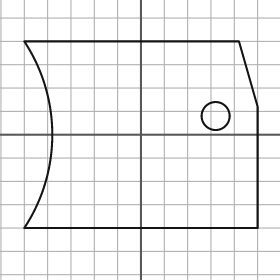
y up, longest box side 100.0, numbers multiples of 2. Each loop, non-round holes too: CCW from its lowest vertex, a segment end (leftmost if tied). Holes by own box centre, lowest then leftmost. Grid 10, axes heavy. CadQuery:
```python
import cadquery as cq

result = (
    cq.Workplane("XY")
    .moveTo(-50.0, -40.0)
    .lineTo(50.0, -40.0)
    .lineTo(50.0, 12.0)
    .lineTo(42.0, 40.0)
    .lineTo(-50.0, 40.0)
    .threePointArc((-38.0, 0.0), (-50.0, -40.0))
    .close()
    .moveTo(32.0, 8.0)
    .circle(6.0)
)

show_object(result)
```